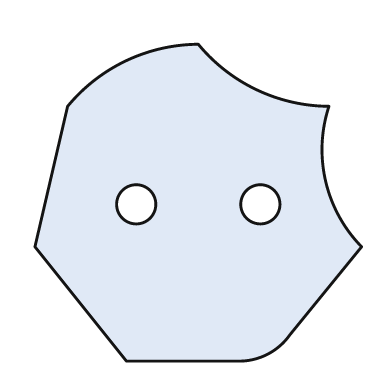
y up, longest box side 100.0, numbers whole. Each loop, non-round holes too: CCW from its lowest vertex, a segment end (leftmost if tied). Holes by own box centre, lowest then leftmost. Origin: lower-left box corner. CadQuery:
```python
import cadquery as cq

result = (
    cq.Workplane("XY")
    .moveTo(28.0, 0.0)
    .lineTo(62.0, 0.0)
    .threePointArc((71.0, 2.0), (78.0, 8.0))
    .lineTo(100.0, 35.0)
    .threePointArc((89.0, 55.0), (90.0, 78.0))
    .threePointArc((68.0, 83.0), (50.0, 97.0))
    .threePointArc((28.0, 92.0), (10.0, 78.0))
    .lineTo(0.0, 35.0)
    .close()
    .moveTo(31.0, 48.0)
    .circle(6.0)
    .moveTo(69.0, 48.0)
    .circle(6.0)
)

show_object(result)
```